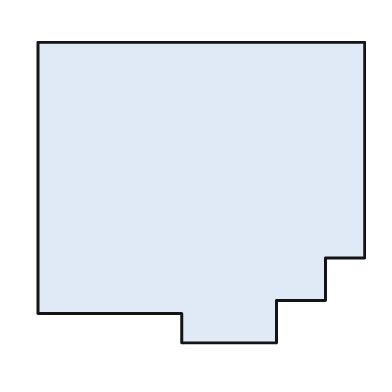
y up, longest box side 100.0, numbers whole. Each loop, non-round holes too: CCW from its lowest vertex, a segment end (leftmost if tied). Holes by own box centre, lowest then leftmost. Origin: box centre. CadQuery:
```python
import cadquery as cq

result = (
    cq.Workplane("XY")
    .moveTo(-6.0, -46.0)
    .lineTo(23.0, -46.0)
    .lineTo(23.0, -33.0)
    .lineTo(38.0, -33.0)
    .lineTo(38.0, -20.0)
    .lineTo(50.0, -20.0)
    .lineTo(50.0, 46.0)
    .lineTo(-50.0, 46.0)
    .lineTo(-50.0, -37.0)
    .lineTo(-6.0, -37.0)
    .close()
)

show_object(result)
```